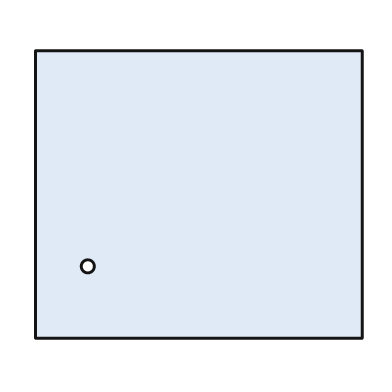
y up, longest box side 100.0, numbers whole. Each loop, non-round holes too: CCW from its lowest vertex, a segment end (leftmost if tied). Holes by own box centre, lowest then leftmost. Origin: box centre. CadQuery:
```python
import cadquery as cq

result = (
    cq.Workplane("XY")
    .moveTo(-50.0, -44.0)
    .lineTo(50.0, -44.0)
    .lineTo(50.0, 44.0)
    .lineTo(-50.0, 44.0)
    .close()
    .moveTo(-34.0, -22.0)
    .circle(2.0)
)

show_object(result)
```